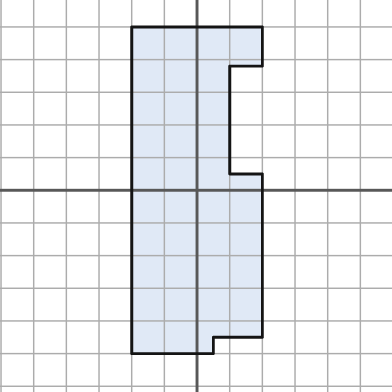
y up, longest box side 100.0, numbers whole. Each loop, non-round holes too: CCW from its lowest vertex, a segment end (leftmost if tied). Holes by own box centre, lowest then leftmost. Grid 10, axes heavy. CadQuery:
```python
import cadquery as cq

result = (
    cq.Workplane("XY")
    .moveTo(-20.0, -50.0)
    .lineTo(5.0, -50.0)
    .lineTo(5.0, -45.0)
    .lineTo(20.0, -45.0)
    .lineTo(20.0, 5.0)
    .lineTo(10.0, 5.0)
    .lineTo(10.0, 38.0)
    .lineTo(20.0, 38.0)
    .lineTo(20.0, 50.0)
    .lineTo(-20.0, 50.0)
    .close()
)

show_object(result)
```